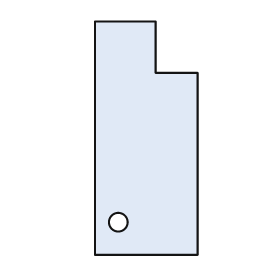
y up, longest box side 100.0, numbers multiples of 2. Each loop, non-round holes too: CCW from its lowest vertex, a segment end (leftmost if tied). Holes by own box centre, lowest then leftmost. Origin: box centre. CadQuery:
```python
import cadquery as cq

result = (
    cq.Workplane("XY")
    .moveTo(-22.0, -50.0)
    .lineTo(22.0, -50.0)
    .lineTo(22.0, 28.0)
    .lineTo(4.0, 28.0)
    .lineTo(4.0, 50.0)
    .lineTo(-22.0, 50.0)
    .close()
    .moveTo(-12.0, -36.0)
    .circle(4.0)
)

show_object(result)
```